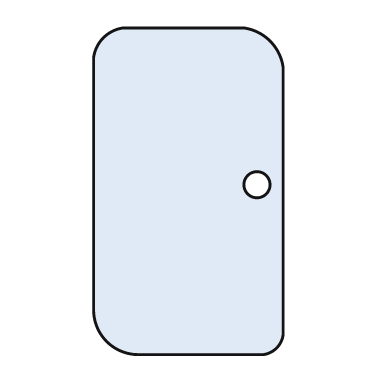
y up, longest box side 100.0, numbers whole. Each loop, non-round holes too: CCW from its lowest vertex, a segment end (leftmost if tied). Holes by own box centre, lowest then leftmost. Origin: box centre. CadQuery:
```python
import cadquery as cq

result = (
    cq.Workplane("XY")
    .moveTo(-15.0, -50.0)
    .lineTo(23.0, -50.0)
    .threePointArc((27.0, -48.0), (29.0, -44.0))
    .lineTo(29.0, 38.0)
    .threePointArc((25.0, 46.0), (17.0, 50.0))
    .lineTo(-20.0, 50.0)
    .threePointArc((-26.0, 47.0), (-29.0, 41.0))
    .lineTo(-29.0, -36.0)
    .threePointArc((-25.0, -46.0), (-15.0, -50.0))
    .close()
    .moveTo(21.0, 2.0)
    .circle(4.0)
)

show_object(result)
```